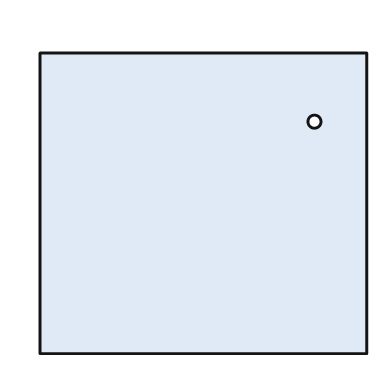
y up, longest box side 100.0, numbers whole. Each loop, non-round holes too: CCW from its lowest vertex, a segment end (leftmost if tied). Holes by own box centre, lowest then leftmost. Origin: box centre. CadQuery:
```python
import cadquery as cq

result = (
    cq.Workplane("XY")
    .moveTo(-50.0, -46.0)
    .lineTo(50.0, -46.0)
    .lineTo(50.0, 46.0)
    .lineTo(-50.0, 46.0)
    .close()
    .moveTo(34.0, 25.0)
    .circle(2.0)
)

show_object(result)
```